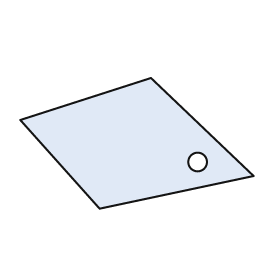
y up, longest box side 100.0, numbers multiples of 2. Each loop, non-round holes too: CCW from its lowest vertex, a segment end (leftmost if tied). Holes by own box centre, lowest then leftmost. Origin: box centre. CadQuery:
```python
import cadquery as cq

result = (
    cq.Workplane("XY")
    .moveTo(-16.0, -28.0)
    .lineTo(50.0, -14.0)
    .lineTo(6.0, 28.0)
    .lineTo(-50.0, 10.0)
    .close()
    .moveTo(26.0, -8.0)
    .circle(4.0)
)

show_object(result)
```